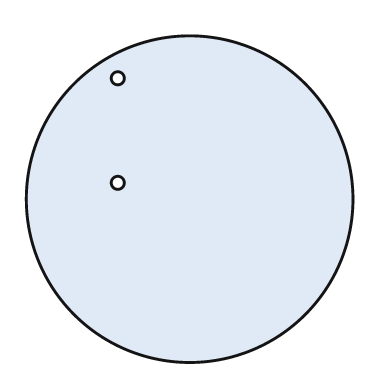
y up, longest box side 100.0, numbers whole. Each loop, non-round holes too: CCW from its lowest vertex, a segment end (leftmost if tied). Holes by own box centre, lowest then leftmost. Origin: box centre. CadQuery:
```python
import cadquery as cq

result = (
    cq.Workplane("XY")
    .moveTo(0.0, 0.0)
    .circle(50.0)
    .moveTo(-22.0, 5.0)
    .circle(2.0)
    .moveTo(-22.0, 37.0)
    .circle(2.0)
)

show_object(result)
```